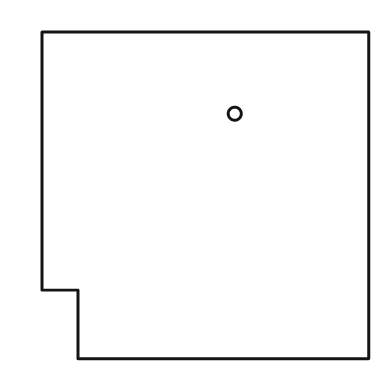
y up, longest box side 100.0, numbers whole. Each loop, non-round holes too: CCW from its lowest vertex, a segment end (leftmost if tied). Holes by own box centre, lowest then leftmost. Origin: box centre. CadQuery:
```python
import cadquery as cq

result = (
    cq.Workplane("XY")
    .moveTo(-39.0, -50.0)
    .lineTo(50.0, -50.0)
    .lineTo(50.0, 50.0)
    .lineTo(-50.0, 50.0)
    .lineTo(-50.0, -29.0)
    .lineTo(-39.0, -29.0)
    .close()
    .moveTo(9.0, 25.0)
    .circle(2.0)
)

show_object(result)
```